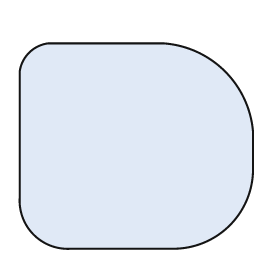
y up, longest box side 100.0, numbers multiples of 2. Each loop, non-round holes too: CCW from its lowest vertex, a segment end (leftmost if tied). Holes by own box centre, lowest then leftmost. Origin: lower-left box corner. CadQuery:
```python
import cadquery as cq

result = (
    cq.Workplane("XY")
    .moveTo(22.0, 0.0)
    .lineTo(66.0, 0.0)
    .threePointArc((90.0, 10.0), (100.0, 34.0))
    .lineTo(100.0, 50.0)
    .threePointArc((88.0, 76.0), (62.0, 88.0))
    .lineTo(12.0, 88.0)
    .threePointArc((4.0, 84.0), (0.0, 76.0))
    .lineTo(0.0, 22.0)
    .threePointArc((6.0, 6.0), (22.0, 0.0))
    .close()
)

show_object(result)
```